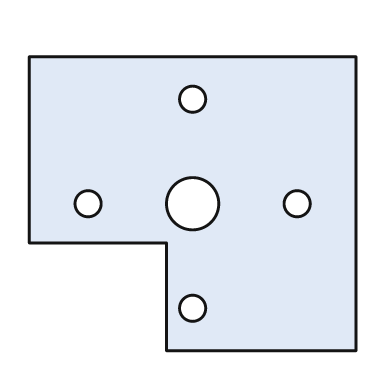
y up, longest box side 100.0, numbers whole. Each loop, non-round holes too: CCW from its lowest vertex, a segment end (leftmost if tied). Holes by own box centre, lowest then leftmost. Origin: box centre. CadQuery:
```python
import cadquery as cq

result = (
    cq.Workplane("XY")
    .moveTo(-8.0, -45.0)
    .lineTo(50.0, -45.0)
    .lineTo(50.0, 45.0)
    .lineTo(-50.0, 45.0)
    .lineTo(-50.0, -12.0)
    .lineTo(-8.0, -12.0)
    .close()
    .moveTo(0.0, -32.0)
    .circle(4.0)
    .moveTo(-32.0, 0.0)
    .circle(4.0)
    .moveTo(0.0, 0.0)
    .circle(8.0)
    .moveTo(32.0, 0.0)
    .circle(4.0)
    .moveTo(0.0, 32.0)
    .circle(4.0)
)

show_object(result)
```